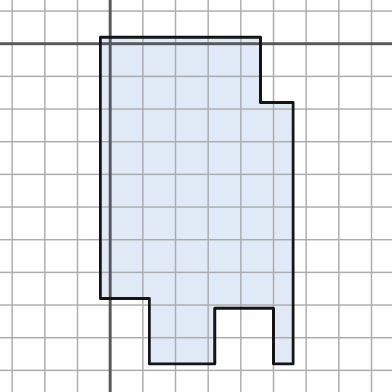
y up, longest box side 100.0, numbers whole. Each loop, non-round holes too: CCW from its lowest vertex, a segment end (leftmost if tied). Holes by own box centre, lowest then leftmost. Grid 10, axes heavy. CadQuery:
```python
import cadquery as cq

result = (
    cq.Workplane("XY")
    .moveTo(12.0, -98.0)
    .lineTo(32.0, -98.0)
    .lineTo(32.0, -81.0)
    .lineTo(50.0, -81.0)
    .lineTo(50.0, -98.0)
    .lineTo(56.0, -98.0)
    .lineTo(56.0, -18.0)
    .lineTo(46.0, -18.0)
    .lineTo(46.0, 2.0)
    .lineTo(-3.0, 2.0)
    .lineTo(-3.0, -78.0)
    .lineTo(12.0, -78.0)
    .close()
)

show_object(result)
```